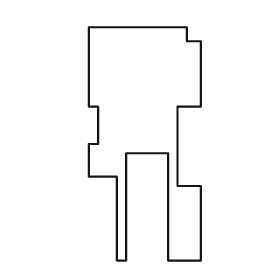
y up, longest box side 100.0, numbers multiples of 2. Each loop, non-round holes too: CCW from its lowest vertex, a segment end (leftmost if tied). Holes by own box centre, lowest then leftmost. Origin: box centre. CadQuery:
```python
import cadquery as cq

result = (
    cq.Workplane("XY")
    .moveTo(-12.0, -50.0)
    .lineTo(-8.0, -50.0)
    .lineTo(-8.0, -4.0)
    .lineTo(10.0, -4.0)
    .lineTo(10.0, -50.0)
    .lineTo(24.0, -50.0)
    .lineTo(24.0, -18.0)
    .lineTo(14.0, -18.0)
    .lineTo(14.0, 16.0)
    .lineTo(24.0, 16.0)
    .lineTo(24.0, 44.0)
    .lineTo(18.0, 44.0)
    .lineTo(18.0, 50.0)
    .lineTo(-24.0, 50.0)
    .lineTo(-24.0, 16.0)
    .lineTo(-20.0, 16.0)
    .lineTo(-20.0, 0.0)
    .lineTo(-24.0, 0.0)
    .lineTo(-24.0, -14.0)
    .lineTo(-12.0, -14.0)
    .close()
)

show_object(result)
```